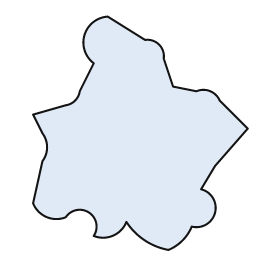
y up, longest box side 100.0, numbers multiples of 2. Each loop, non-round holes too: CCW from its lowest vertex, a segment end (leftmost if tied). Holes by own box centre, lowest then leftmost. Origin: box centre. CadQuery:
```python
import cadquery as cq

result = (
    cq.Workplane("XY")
    .moveTo(12.0, -50.0)
    .threePointArc((18.0, -46.0), (22.0, -40.0))
    .threePointArc((32.0, -34.0), (26.0, -24.0))
    .lineTo(32.0, -14.0)
    .lineTo(46.0, 2.0)
    .lineTo(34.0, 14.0)
    .threePointArc((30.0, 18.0), (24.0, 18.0))
    .lineTo(14.0, 20.0)
    .lineTo(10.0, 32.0)
    .threePointArc((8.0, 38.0), (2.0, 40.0))
    .lineTo(-14.0, 50.0)
    .threePointArc((-24.0, 42.0), (-20.0, 30.0))
    .lineTo(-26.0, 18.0)
    .threePointArc((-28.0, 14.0), (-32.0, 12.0))
    .lineTo(-46.0, 8.0)
    .lineTo(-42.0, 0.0)
    .threePointArc((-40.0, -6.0), (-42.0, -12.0))
    .lineTo(-46.0, -30.0)
    .threePointArc((-40.0, -36.0), (-32.0, -36.0))
    .threePointArc((-22.0, -34.0), (-20.0, -44.0))
    .threePointArc((-12.0, -44.0), (-6.0, -38.0))
    .threePointArc((2.0, -46.0), (12.0, -50.0))
    .close()
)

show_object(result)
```